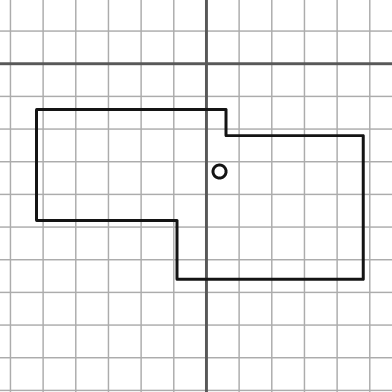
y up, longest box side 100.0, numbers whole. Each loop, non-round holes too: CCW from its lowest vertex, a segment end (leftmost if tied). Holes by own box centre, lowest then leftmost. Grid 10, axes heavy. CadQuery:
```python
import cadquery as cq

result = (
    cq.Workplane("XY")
    .moveTo(-9.0, -66.0)
    .lineTo(48.0, -66.0)
    .lineTo(48.0, -22.0)
    .lineTo(6.0, -22.0)
    .lineTo(6.0, -14.0)
    .lineTo(-52.0, -14.0)
    .lineTo(-52.0, -48.0)
    .lineTo(-9.0, -48.0)
    .close()
    .moveTo(4.0, -33.0)
    .circle(2.0)
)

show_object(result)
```